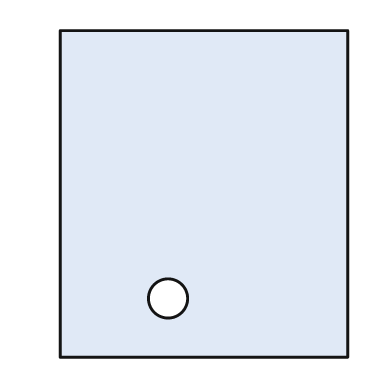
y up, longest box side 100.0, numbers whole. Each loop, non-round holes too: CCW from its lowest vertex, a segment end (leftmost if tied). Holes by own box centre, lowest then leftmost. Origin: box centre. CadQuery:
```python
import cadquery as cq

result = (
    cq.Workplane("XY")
    .moveTo(-44.0, -50.0)
    .lineTo(44.0, -50.0)
    .lineTo(44.0, 50.0)
    .lineTo(-44.0, 50.0)
    .close()
    .moveTo(-11.0, -32.0)
    .circle(6.0)
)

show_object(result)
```